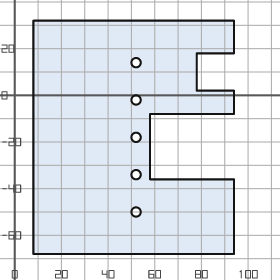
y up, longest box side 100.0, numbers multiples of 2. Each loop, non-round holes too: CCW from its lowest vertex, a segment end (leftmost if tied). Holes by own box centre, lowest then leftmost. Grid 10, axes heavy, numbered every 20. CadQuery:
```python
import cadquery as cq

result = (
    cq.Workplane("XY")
    .moveTo(8.0, -68.0)
    .lineTo(94.0, -68.0)
    .lineTo(94.0, -36.0)
    .lineTo(58.0, -36.0)
    .lineTo(58.0, -8.0)
    .lineTo(94.0, -8.0)
    .lineTo(94.0, 2.0)
    .lineTo(78.0, 2.0)
    .lineTo(78.0, 18.0)
    .lineTo(94.0, 18.0)
    .lineTo(94.0, 32.0)
    .lineTo(8.0, 32.0)
    .close()
    .moveTo(52.0, -50.0)
    .circle(2.0)
    .moveTo(52.0, -34.0)
    .circle(2.0)
    .moveTo(52.0, -18.0)
    .circle(2.0)
    .moveTo(52.0, -2.0)
    .circle(2.0)
    .moveTo(52.0, 14.0)
    .circle(2.0)
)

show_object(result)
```